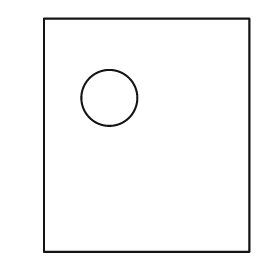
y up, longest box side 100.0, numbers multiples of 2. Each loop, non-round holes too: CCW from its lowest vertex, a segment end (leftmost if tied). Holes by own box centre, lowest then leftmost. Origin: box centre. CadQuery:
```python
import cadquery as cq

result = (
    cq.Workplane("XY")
    .moveTo(-44.0, -50.0)
    .lineTo(44.0, -50.0)
    .lineTo(44.0, 50.0)
    .lineTo(-44.0, 50.0)
    .close()
    .moveTo(-16.0, 16.0)
    .circle(12.0)
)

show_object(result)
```